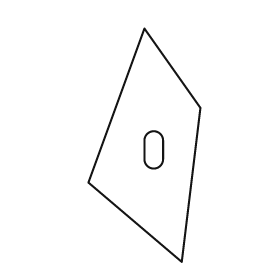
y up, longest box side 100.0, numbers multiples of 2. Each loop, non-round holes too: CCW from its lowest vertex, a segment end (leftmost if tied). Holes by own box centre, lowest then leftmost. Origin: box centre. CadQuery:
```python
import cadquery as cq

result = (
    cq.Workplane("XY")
    .moveTo(16.0, -50.0)
    .lineTo(24.0, 16.0)
    .lineTo(0.0, 50.0)
    .lineTo(-24.0, -16.0)
    .close()
    .moveTo(0.0, -6.0)
    .threePointArc((4.0, -10.0), (8.0, -6.0))
    .lineTo(8.0, 2.0)
    .threePointArc((4.0, 6.0), (0.0, 2.0))
    .close()
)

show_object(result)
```